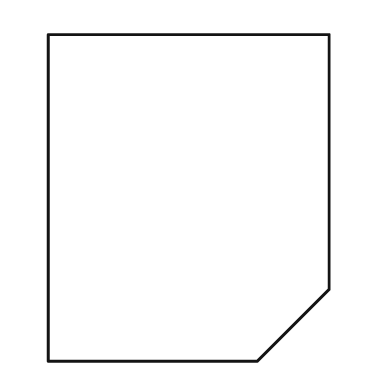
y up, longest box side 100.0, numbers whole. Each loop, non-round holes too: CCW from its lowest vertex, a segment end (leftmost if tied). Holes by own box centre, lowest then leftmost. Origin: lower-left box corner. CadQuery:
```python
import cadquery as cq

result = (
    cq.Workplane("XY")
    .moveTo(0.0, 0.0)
    .lineTo(64.0, 0.0)
    .lineTo(86.0, 22.0)
    .lineTo(86.0, 100.0)
    .lineTo(0.0, 100.0)
    .close()
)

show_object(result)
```